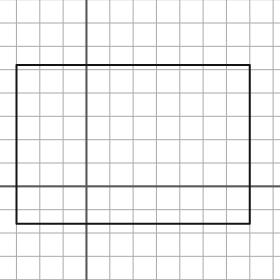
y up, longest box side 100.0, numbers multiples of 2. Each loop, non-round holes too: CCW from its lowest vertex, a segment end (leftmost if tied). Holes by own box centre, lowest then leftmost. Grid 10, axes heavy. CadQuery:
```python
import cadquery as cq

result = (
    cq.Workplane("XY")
    .moveTo(-30.0, -16.0)
    .lineTo(70.0, -16.0)
    .lineTo(70.0, 52.0)
    .lineTo(-30.0, 52.0)
    .close()
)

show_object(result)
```